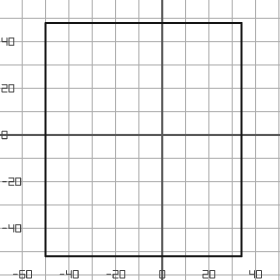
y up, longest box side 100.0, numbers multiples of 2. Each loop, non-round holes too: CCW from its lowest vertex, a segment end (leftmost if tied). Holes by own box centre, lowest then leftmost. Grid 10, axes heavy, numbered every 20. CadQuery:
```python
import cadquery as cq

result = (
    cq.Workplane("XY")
    .moveTo(-50.0, -52.0)
    .lineTo(34.0, -52.0)
    .lineTo(34.0, 48.0)
    .lineTo(-50.0, 48.0)
    .close()
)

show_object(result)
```